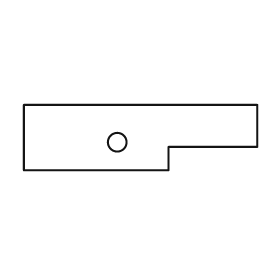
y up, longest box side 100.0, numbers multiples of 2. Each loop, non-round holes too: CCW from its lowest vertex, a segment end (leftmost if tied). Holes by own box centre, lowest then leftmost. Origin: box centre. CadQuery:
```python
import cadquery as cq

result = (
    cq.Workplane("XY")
    .moveTo(-50.0, -14.0)
    .lineTo(12.0, -14.0)
    .lineTo(12.0, -4.0)
    .lineTo(50.0, -4.0)
    .lineTo(50.0, 14.0)
    .lineTo(-50.0, 14.0)
    .close()
    .moveTo(-10.0, -2.0)
    .circle(4.0)
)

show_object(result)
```